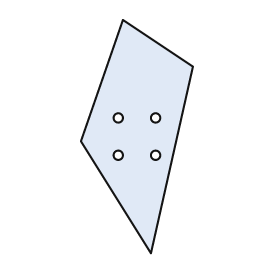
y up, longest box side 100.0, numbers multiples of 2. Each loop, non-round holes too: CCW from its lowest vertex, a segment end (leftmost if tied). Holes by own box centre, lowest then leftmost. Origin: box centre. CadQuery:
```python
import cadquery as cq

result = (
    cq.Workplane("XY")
    .moveTo(6.0, -50.0)
    .lineTo(24.0, 30.0)
    .lineTo(-6.0, 50.0)
    .lineTo(-24.0, -2.0)
    .close()
    .moveTo(-8.0, -8.0)
    .circle(2.0)
    .moveTo(8.0, -8.0)
    .circle(2.0)
    .moveTo(-8.0, 8.0)
    .circle(2.0)
    .moveTo(8.0, 8.0)
    .circle(2.0)
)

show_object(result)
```